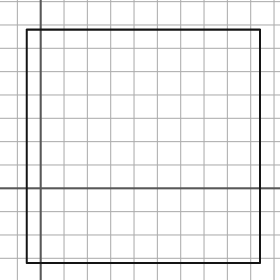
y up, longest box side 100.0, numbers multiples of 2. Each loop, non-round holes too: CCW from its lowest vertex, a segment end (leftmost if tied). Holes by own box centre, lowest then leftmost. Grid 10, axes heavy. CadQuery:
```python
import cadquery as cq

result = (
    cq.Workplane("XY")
    .moveTo(-6.0, -32.0)
    .lineTo(94.0, -32.0)
    .lineTo(94.0, 68.0)
    .lineTo(-6.0, 68.0)
    .close()
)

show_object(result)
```